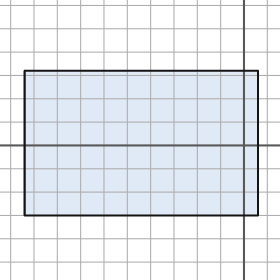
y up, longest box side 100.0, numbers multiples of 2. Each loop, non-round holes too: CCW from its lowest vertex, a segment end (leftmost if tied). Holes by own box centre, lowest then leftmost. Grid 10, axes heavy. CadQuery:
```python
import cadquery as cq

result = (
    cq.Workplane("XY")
    .moveTo(-94.0, -30.0)
    .lineTo(6.0, -30.0)
    .lineTo(6.0, 32.0)
    .lineTo(-94.0, 32.0)
    .close()
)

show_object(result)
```